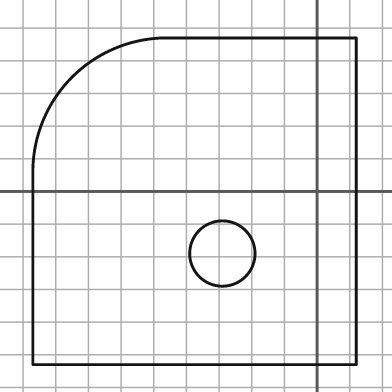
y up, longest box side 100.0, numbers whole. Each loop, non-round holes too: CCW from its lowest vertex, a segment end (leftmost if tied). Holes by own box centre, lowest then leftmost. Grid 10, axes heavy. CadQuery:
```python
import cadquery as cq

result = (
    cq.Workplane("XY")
    .moveTo(-87.0, -53.0)
    .lineTo(12.0, -53.0)
    .lineTo(12.0, 47.0)
    .lineTo(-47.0, 47.0)
    .threePointArc((-75.0, 35.0), (-87.0, 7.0))
    .close()
    .moveTo(-29.0, -19.0)
    .circle(10.0)
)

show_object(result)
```